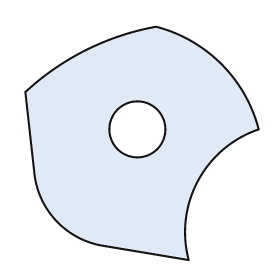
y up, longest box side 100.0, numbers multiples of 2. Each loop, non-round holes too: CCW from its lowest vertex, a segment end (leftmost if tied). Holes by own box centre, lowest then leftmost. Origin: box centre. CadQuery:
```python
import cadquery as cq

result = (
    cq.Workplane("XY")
    .moveTo(20.0, -50.0)
    .threePointArc((24.0, -16.0), (50.0, 6.0))
    .threePointArc((34.0, 34.0), (6.0, 50.0))
    .threePointArc((-24.0, 40.0), (-50.0, 22.0))
    .lineTo(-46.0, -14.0)
    .threePointArc((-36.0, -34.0), (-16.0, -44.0))
    .close()
    .moveTo(-2.0, 6.0)
    .circle(12.0)
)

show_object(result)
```